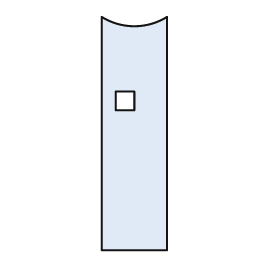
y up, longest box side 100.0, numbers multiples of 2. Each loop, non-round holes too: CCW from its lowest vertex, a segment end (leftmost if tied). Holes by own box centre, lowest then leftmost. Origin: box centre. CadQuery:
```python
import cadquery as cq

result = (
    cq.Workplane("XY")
    .moveTo(-14.0, -50.0)
    .lineTo(14.0, -50.0)
    .lineTo(14.0, 50.0)
    .threePointArc((0.0, 46.0), (-14.0, 50.0))
    .close()
    .moveTo(-8.0, 10.0)
    .lineTo(0.0, 10.0)
    .lineTo(0.0, 18.0)
    .lineTo(-8.0, 18.0)
    .close()
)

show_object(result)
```